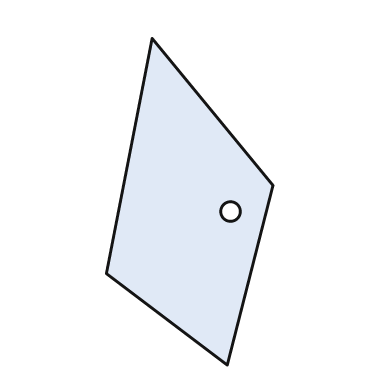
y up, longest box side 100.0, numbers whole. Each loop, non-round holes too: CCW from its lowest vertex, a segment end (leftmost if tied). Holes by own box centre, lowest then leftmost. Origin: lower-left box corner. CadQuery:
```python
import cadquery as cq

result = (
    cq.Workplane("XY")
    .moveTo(37.0, 0.0)
    .lineTo(51.0, 55.0)
    .lineTo(14.0, 100.0)
    .lineTo(0.0, 28.0)
    .close()
    .moveTo(38.0, 47.0)
    .circle(3.0)
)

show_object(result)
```